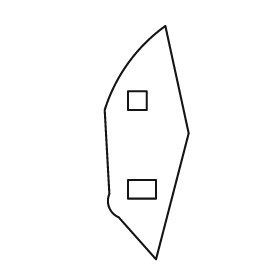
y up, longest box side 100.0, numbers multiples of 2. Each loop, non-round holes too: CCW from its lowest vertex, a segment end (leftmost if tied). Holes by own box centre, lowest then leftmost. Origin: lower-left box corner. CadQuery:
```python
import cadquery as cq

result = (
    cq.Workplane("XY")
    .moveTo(22.0, 0.0)
    .lineTo(36.0, 54.0)
    .lineTo(26.0, 100.0)
    .threePointArc((10.0, 84.0), (0.0, 64.0))
    .lineTo(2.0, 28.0)
    .threePointArc((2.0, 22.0), (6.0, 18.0))
    .close()
    .moveTo(10.0, 26.0)
    .lineTo(22.0, 26.0)
    .lineTo(22.0, 34.0)
    .lineTo(10.0, 34.0)
    .close()
    .moveTo(10.0, 64.0)
    .lineTo(18.0, 64.0)
    .lineTo(18.0, 72.0)
    .lineTo(10.0, 72.0)
    .close()
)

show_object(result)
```